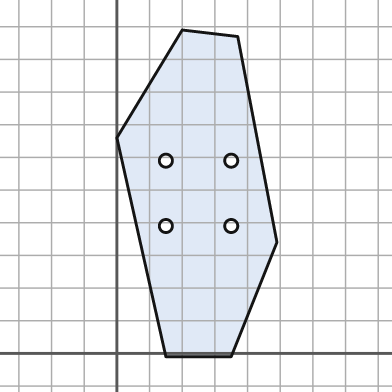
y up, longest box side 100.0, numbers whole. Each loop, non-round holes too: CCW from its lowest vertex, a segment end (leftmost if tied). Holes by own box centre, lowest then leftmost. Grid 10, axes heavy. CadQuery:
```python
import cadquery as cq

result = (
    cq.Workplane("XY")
    .moveTo(15.0, -1.0)
    .lineTo(35.0, -1.0)
    .lineTo(49.0, 34.0)
    .lineTo(37.0, 97.0)
    .lineTo(20.0, 99.0)
    .lineTo(0.0, 66.0)
    .close()
    .moveTo(15.0, 39.0)
    .circle(2.0)
    .moveTo(35.0, 39.0)
    .circle(2.0)
    .moveTo(15.0, 59.0)
    .circle(2.0)
    .moveTo(35.0, 59.0)
    .circle(2.0)
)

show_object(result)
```